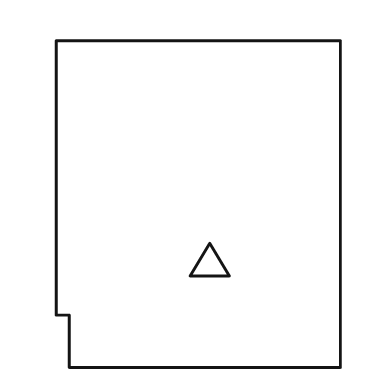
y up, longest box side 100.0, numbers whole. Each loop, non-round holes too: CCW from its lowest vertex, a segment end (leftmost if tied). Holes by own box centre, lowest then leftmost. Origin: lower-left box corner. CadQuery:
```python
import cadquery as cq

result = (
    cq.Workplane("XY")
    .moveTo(4.0, 0.0)
    .lineTo(87.0, 0.0)
    .lineTo(87.0, 100.0)
    .lineTo(0.0, 100.0)
    .lineTo(0.0, 16.0)
    .lineTo(4.0, 16.0)
    .close()
    .moveTo(41.0, 28.0)
    .lineTo(53.0, 28.0)
    .lineTo(47.0, 38.0)
    .close()
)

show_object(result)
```